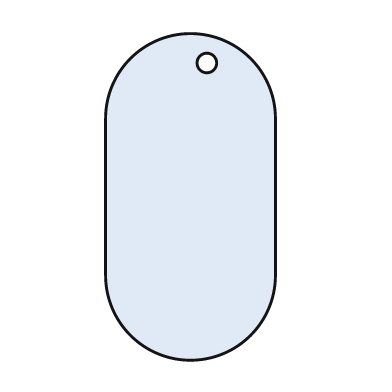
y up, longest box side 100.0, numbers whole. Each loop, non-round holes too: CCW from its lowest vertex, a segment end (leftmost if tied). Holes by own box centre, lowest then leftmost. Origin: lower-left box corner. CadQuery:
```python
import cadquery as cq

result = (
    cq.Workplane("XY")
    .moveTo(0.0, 26.0)
    .threePointArc((26.0, 0.0), (52.0, 26.0))
    .lineTo(52.0, 74.0)
    .threePointArc((26.0, 100.0), (0.0, 74.0))
    .close()
    .moveTo(31.0, 91.0)
    .circle(3.0)
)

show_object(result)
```